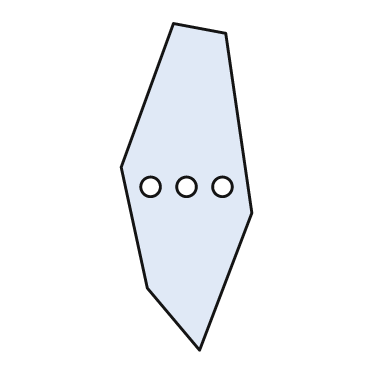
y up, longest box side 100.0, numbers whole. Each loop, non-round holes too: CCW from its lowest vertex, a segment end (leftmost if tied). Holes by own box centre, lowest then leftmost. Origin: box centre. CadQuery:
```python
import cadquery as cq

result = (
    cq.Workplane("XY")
    .moveTo(4.0, -50.0)
    .lineTo(20.0, -8.0)
    .lineTo(12.0, 47.0)
    .lineTo(-4.0, 50.0)
    .lineTo(-20.0, 6.0)
    .lineTo(-12.0, -31.0)
    .close()
    .moveTo(-11.0, 0.0)
    .circle(3.0)
    .moveTo(0.0, 0.0)
    .circle(3.0)
    .moveTo(11.0, 0.0)
    .circle(3.0)
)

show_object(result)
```